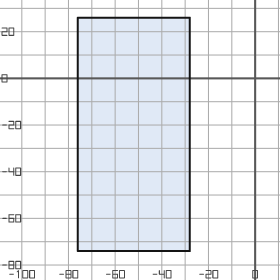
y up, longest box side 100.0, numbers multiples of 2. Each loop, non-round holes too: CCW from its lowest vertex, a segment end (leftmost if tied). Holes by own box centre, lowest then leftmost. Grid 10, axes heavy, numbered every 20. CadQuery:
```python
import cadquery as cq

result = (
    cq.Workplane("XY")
    .moveTo(-76.0, -74.0)
    .lineTo(-28.0, -74.0)
    .lineTo(-28.0, 26.0)
    .lineTo(-76.0, 26.0)
    .close()
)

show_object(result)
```